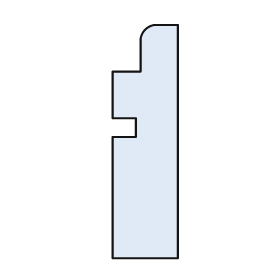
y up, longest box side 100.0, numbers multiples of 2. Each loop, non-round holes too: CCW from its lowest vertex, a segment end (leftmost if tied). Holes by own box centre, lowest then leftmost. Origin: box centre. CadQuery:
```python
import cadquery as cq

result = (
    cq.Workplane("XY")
    .moveTo(-14.0, -50.0)
    .lineTo(14.0, -50.0)
    .lineTo(14.0, 50.0)
    .lineTo(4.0, 50.0)
    .threePointArc((0.0, 48.0), (-2.0, 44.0))
    .lineTo(-2.0, 30.0)
    .lineTo(-14.0, 30.0)
    .lineTo(-14.0, 10.0)
    .lineTo(-4.0, 10.0)
    .lineTo(-4.0, 2.0)
    .lineTo(-14.0, 2.0)
    .close()
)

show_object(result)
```